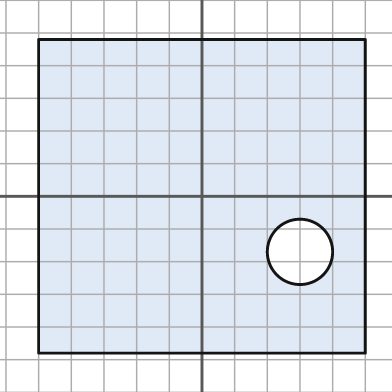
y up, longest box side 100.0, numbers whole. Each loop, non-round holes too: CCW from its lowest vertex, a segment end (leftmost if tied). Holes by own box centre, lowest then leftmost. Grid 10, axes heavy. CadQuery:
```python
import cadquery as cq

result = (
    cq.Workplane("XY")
    .moveTo(-50.0, -48.0)
    .lineTo(50.0, -48.0)
    .lineTo(50.0, 48.0)
    .lineTo(-50.0, 48.0)
    .close()
    .moveTo(30.0, -17.0)
    .circle(10.0)
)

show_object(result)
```